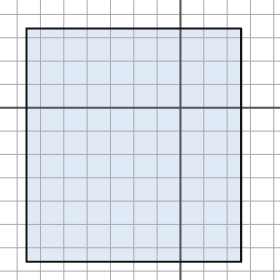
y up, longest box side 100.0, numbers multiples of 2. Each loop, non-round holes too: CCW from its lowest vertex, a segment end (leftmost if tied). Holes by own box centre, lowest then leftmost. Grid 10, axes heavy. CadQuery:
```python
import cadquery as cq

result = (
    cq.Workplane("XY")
    .moveTo(-66.0, -66.0)
    .lineTo(26.0, -66.0)
    .lineTo(26.0, 34.0)
    .lineTo(-66.0, 34.0)
    .close()
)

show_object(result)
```